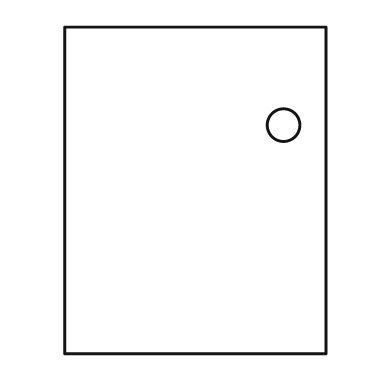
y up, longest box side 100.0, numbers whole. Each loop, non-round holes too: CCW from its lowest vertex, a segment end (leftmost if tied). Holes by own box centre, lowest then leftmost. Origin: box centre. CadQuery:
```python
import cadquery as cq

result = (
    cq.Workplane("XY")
    .moveTo(-40.0, -50.0)
    .lineTo(40.0, -50.0)
    .lineTo(40.0, 50.0)
    .lineTo(-40.0, 50.0)
    .close()
    .moveTo(27.0, 20.0)
    .circle(5.0)
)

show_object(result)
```